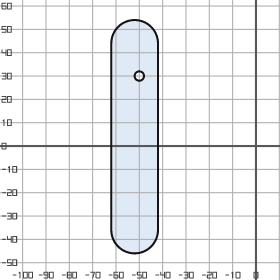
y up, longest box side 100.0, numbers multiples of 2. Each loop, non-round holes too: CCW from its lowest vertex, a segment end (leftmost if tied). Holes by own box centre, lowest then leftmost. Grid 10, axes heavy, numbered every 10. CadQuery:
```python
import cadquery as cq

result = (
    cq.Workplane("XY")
    .moveTo(-62.0, -36.0)
    .threePointArc((-52.0, -46.0), (-42.0, -36.0))
    .lineTo(-42.0, 44.0)
    .threePointArc((-52.0, 54.0), (-62.0, 44.0))
    .close()
    .moveTo(-50.0, 30.0)
    .circle(2.0)
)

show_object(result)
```